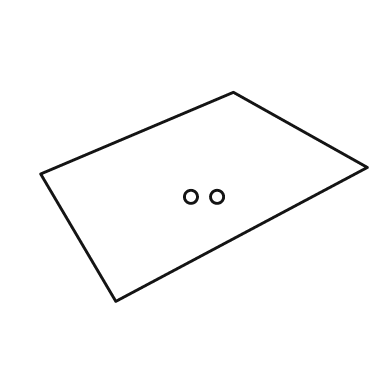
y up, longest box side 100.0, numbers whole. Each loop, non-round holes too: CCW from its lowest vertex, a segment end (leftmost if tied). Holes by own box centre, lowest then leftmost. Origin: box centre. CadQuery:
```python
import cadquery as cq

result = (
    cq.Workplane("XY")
    .moveTo(-27.0, -32.0)
    .lineTo(50.0, 9.0)
    .lineTo(9.0, 32.0)
    .lineTo(-50.0, 7.0)
    .close()
    .moveTo(-4.0, 0.0)
    .circle(2.0)
    .moveTo(4.0, 0.0)
    .circle(2.0)
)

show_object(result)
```